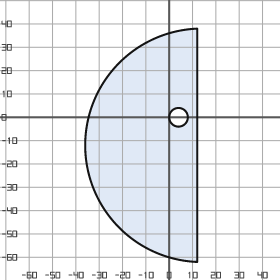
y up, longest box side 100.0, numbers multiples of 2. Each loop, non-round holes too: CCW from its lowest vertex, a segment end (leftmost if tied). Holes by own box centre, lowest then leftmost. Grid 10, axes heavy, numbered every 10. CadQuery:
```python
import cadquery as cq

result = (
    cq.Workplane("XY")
    .moveTo(12.0, -62.0)
    .lineTo(12.0, 38.0)
    .threePointArc((-36.0, -12.0), (12.0, -62.0))
    .close()
    .moveTo(4.0, 0.0)
    .circle(4.0)
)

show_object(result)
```